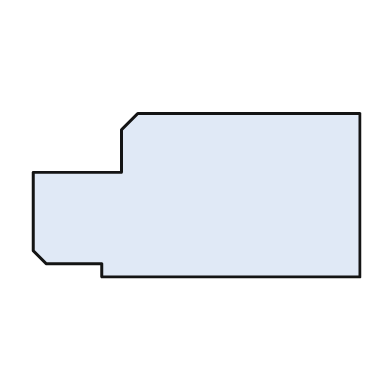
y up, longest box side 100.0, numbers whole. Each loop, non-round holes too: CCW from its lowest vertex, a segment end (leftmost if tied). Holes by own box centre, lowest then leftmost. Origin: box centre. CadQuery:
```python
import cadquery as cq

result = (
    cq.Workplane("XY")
    .moveTo(-29.0, -25.0)
    .lineTo(50.0, -25.0)
    .lineTo(50.0, 25.0)
    .lineTo(-18.0, 25.0)
    .lineTo(-23.0, 20.0)
    .lineTo(-23.0, 7.0)
    .lineTo(-50.0, 7.0)
    .lineTo(-50.0, -17.0)
    .lineTo(-46.0, -21.0)
    .lineTo(-29.0, -21.0)
    .close()
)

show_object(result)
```